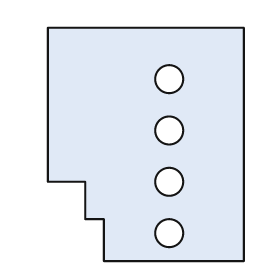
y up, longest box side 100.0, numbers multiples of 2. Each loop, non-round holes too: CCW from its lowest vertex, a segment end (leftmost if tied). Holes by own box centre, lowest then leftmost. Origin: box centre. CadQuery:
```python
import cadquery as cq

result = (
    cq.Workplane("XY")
    .moveTo(-18.0, -50.0)
    .lineTo(42.0, -50.0)
    .lineTo(42.0, 50.0)
    .lineTo(-42.0, 50.0)
    .lineTo(-42.0, -16.0)
    .lineTo(-26.0, -16.0)
    .lineTo(-26.0, -32.0)
    .lineTo(-18.0, -32.0)
    .close()
    .moveTo(10.0, -38.0)
    .circle(6.0)
    .moveTo(10.0, -16.0)
    .circle(6.0)
    .moveTo(10.0, 6.0)
    .circle(6.0)
    .moveTo(10.0, 28.0)
    .circle(6.0)
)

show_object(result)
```